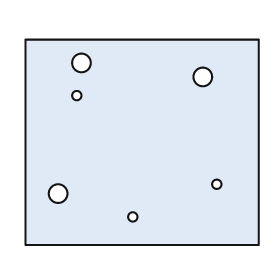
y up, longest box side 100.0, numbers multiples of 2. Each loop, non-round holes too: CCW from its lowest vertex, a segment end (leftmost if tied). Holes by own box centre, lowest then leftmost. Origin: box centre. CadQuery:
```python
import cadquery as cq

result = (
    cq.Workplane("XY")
    .moveTo(-50.0, -44.0)
    .lineTo(50.0, -44.0)
    .lineTo(50.0, 44.0)
    .lineTo(-50.0, 44.0)
    .close()
    .moveTo(-4.0, -32.0)
    .circle(2.0)
    .moveTo(-36.0, -22.0)
    .circle(4.0)
    .moveTo(32.0, -18.0)
    .circle(2.0)
    .moveTo(-28.0, 20.0)
    .circle(2.0)
    .moveTo(26.0, 28.0)
    .circle(4.0)
    .moveTo(-26.0, 34.0)
    .circle(4.0)
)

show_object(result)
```